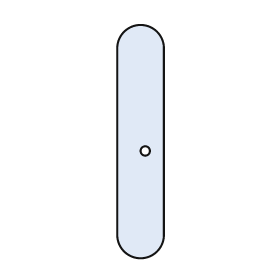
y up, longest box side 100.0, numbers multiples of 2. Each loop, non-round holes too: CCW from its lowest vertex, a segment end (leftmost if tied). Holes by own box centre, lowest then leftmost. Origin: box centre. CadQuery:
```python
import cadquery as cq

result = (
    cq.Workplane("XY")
    .moveTo(-10.0, -40.0)
    .threePointArc((0.0, -50.0), (10.0, -40.0))
    .lineTo(10.0, 40.0)
    .threePointArc((0.0, 50.0), (-10.0, 40.0))
    .close()
    .moveTo(2.0, -4.0)
    .circle(2.0)
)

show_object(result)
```